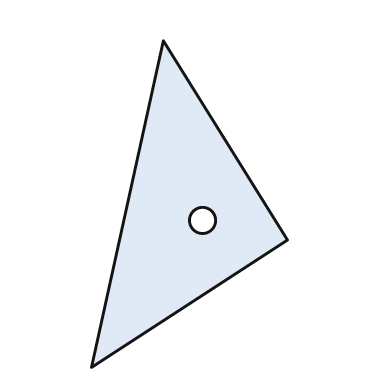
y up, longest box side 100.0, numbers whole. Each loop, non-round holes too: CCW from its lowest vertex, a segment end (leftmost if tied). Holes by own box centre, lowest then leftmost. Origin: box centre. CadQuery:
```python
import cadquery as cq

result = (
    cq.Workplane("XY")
    .moveTo(-30.0, -50.0)
    .lineTo(30.0, -11.0)
    .lineTo(-8.0, 50.0)
    .close()
    .moveTo(4.0, -5.0)
    .circle(4.0)
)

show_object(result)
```